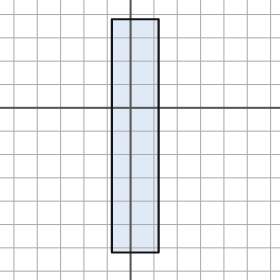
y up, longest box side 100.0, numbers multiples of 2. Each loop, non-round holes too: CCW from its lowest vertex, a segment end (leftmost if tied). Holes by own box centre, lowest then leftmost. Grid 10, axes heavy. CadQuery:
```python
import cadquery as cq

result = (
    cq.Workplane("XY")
    .moveTo(-8.0, -62.0)
    .lineTo(12.0, -62.0)
    .lineTo(12.0, 38.0)
    .lineTo(-8.0, 38.0)
    .close()
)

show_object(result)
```